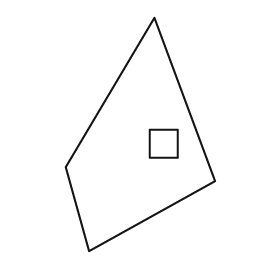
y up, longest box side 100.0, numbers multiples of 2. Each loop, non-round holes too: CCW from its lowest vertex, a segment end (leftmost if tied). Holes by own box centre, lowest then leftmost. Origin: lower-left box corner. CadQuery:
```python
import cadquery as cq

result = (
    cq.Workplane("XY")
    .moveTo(10.0, 0.0)
    .lineTo(64.0, 30.0)
    .lineTo(38.0, 100.0)
    .lineTo(0.0, 36.0)
    .close()
    .moveTo(36.0, 40.0)
    .lineTo(48.0, 40.0)
    .lineTo(48.0, 52.0)
    .lineTo(36.0, 52.0)
    .close()
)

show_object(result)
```